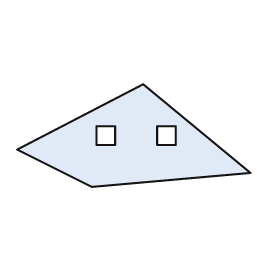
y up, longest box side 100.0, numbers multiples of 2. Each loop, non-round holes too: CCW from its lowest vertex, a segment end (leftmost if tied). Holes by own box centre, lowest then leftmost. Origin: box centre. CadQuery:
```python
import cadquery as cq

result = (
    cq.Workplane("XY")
    .moveTo(-18.0, -22.0)
    .lineTo(50.0, -16.0)
    .lineTo(4.0, 22.0)
    .lineTo(-50.0, -6.0)
    .close()
    .moveTo(-16.0, -4.0)
    .lineTo(-8.0, -4.0)
    .lineTo(-8.0, 4.0)
    .lineTo(-16.0, 4.0)
    .close()
    .moveTo(10.0, -4.0)
    .lineTo(18.0, -4.0)
    .lineTo(18.0, 4.0)
    .lineTo(10.0, 4.0)
    .close()
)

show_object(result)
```